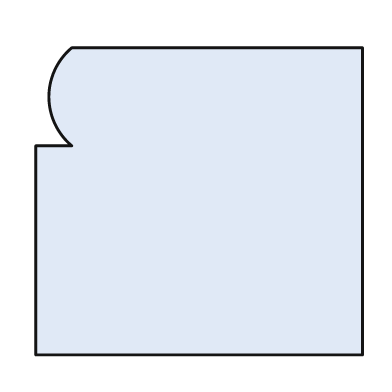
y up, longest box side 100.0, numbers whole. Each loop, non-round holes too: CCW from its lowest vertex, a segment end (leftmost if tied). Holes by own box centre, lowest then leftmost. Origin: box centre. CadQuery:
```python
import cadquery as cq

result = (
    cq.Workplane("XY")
    .moveTo(-50.0, -47.0)
    .lineTo(50.0, -47.0)
    .lineTo(50.0, 47.0)
    .lineTo(-39.0, 47.0)
    .threePointArc((-46.0, 32.0), (-39.0, 17.0))
    .lineTo(-50.0, 17.0)
    .close()
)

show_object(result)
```